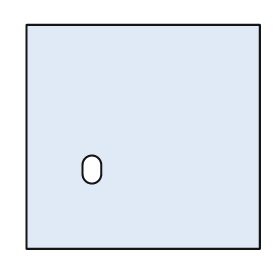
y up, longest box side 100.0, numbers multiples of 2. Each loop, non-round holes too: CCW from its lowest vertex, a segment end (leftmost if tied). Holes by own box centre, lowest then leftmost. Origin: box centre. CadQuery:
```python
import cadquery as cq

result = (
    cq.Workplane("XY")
    .moveTo(-50.0, -48.0)
    .lineTo(50.0, -48.0)
    .lineTo(50.0, 48.0)
    .lineTo(-50.0, 48.0)
    .close()
    .moveTo(-26.0, -16.0)
    .threePointArc((-22.0, -20.0), (-18.0, -16.0))
    .lineTo(-18.0, -12.0)
    .threePointArc((-22.0, -8.0), (-26.0, -12.0))
    .close()
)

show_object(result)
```